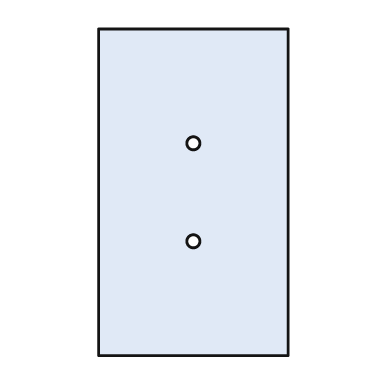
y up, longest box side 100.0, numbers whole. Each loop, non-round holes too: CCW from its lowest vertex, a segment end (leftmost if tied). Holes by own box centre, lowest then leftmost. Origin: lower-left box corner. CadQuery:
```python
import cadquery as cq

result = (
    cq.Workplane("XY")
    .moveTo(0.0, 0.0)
    .lineTo(58.0, 0.0)
    .lineTo(58.0, 100.0)
    .lineTo(0.0, 100.0)
    .close()
    .moveTo(29.0, 35.0)
    .circle(2.0)
    .moveTo(29.0, 65.0)
    .circle(2.0)
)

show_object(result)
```